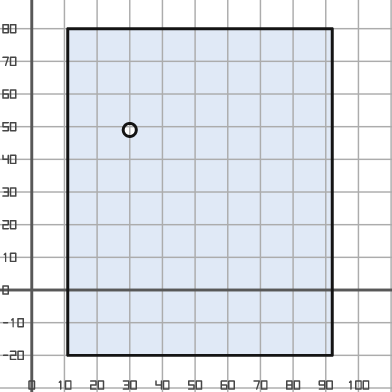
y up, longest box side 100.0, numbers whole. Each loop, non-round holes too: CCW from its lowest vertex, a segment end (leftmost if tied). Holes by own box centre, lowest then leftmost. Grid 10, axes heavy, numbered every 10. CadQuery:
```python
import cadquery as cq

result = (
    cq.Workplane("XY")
    .moveTo(11.0, -20.0)
    .lineTo(92.0, -20.0)
    .lineTo(92.0, 80.0)
    .lineTo(11.0, 80.0)
    .close()
    .moveTo(30.0, 49.0)
    .circle(2.0)
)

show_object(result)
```